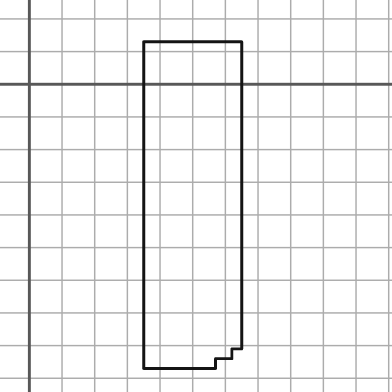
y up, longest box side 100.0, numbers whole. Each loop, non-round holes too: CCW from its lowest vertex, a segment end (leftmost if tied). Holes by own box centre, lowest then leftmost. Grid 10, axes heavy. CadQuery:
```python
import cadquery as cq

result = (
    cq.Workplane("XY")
    .moveTo(35.0, -87.0)
    .lineTo(57.0, -87.0)
    .lineTo(57.0, -84.0)
    .lineTo(62.0, -84.0)
    .lineTo(62.0, -81.0)
    .lineTo(65.0, -81.0)
    .lineTo(65.0, 13.0)
    .lineTo(35.0, 13.0)
    .close()
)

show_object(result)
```